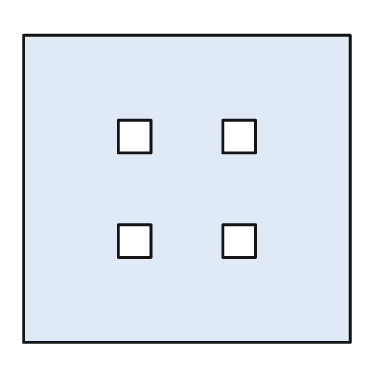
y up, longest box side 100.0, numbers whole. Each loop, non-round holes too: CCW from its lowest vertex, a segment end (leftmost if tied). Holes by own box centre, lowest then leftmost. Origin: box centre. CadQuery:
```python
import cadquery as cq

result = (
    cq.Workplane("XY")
    .moveTo(-50.0, -47.0)
    .lineTo(50.0, -47.0)
    .lineTo(50.0, 47.0)
    .lineTo(-50.0, 47.0)
    .close()
    .moveTo(-21.0, -21.0)
    .lineTo(-11.0, -21.0)
    .lineTo(-11.0, -11.0)
    .lineTo(-21.0, -11.0)
    .close()
    .moveTo(11.0, -21.0)
    .lineTo(21.0, -21.0)
    .lineTo(21.0, -11.0)
    .lineTo(11.0, -11.0)
    .close()
    .moveTo(-21.0, 11.0)
    .lineTo(-11.0, 11.0)
    .lineTo(-11.0, 21.0)
    .lineTo(-21.0, 21.0)
    .close()
    .moveTo(11.0, 11.0)
    .lineTo(21.0, 11.0)
    .lineTo(21.0, 21.0)
    .lineTo(11.0, 21.0)
    .close()
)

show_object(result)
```